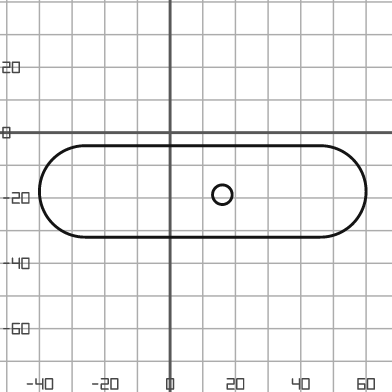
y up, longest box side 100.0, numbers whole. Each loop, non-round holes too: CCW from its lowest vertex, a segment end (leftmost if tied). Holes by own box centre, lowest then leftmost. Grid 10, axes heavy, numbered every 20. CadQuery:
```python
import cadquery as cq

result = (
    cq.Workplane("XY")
    .moveTo(-26.0, -32.0)
    .lineTo(46.0, -32.0)
    .threePointArc((60.0, -18.0), (46.0, -4.0))
    .lineTo(-26.0, -4.0)
    .threePointArc((-40.0, -18.0), (-26.0, -32.0))
    .close()
    .moveTo(16.0, -19.0)
    .circle(3.0)
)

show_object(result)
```